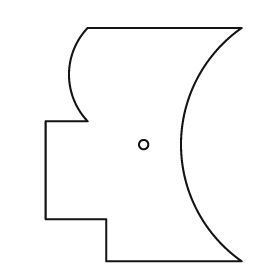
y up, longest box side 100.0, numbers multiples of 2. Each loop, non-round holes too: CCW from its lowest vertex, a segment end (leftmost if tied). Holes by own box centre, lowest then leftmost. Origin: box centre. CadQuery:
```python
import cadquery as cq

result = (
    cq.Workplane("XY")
    .moveTo(-16.0, -50.0)
    .lineTo(42.0, -50.0)
    .threePointArc((16.0, 0.0), (42.0, 50.0))
    .lineTo(-24.0, 50.0)
    .threePointArc((-32.0, 30.0), (-24.0, 10.0))
    .lineTo(-42.0, 10.0)
    .lineTo(-42.0, -32.0)
    .lineTo(-16.0, -32.0)
    .close()
    .moveTo(0.0, 0.0)
    .circle(2.0)
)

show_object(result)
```